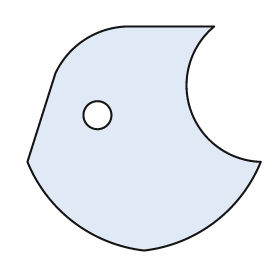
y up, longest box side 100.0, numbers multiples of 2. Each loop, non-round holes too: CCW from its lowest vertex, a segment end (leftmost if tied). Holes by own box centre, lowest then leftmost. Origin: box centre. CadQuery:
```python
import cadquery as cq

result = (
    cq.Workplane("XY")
    .moveTo(0.0, -48.0)
    .threePointArc((30.0, -36.0), (50.0, -10.0))
    .threePointArc((20.0, 12.0), (30.0, 48.0))
    .lineTo(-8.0, 48.0)
    .threePointArc((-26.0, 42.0), (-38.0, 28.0))
    .lineTo(-50.0, -10.0)
    .threePointArc((-30.0, -36.0), (0.0, -48.0))
    .close()
    .moveTo(-20.0, 10.0)
    .circle(6.0)
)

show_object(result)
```